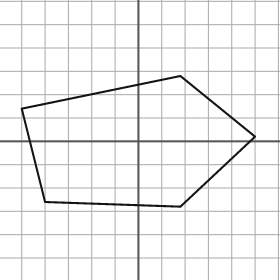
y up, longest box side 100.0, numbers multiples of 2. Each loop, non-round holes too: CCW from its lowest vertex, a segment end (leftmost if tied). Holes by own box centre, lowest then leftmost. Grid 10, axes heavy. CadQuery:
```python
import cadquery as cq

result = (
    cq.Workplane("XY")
    .moveTo(18.0, -28.0)
    .lineTo(50.0, 2.0)
    .lineTo(18.0, 28.0)
    .lineTo(-50.0, 14.0)
    .lineTo(-40.0, -26.0)
    .close()
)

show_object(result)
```